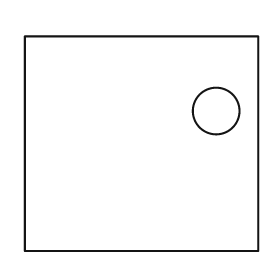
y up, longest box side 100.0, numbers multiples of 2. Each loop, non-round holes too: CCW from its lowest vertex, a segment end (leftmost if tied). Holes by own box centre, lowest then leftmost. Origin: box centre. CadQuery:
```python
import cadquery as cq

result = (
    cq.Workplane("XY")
    .moveTo(-50.0, -46.0)
    .lineTo(50.0, -46.0)
    .lineTo(50.0, 46.0)
    .lineTo(-50.0, 46.0)
    .close()
    .moveTo(32.0, 14.0)
    .circle(10.0)
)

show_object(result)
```